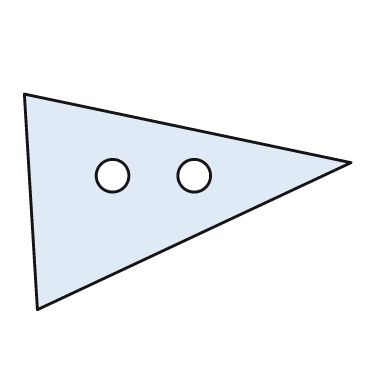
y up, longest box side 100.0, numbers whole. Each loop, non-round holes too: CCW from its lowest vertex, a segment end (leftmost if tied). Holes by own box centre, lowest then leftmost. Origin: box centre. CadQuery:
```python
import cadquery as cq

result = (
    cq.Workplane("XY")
    .moveTo(-46.0, -33.0)
    .lineTo(50.0, 12.0)
    .lineTo(-50.0, 33.0)
    .close()
    .moveTo(-23.0, 8.0)
    .circle(5.0)
    .moveTo(2.0, 8.0)
    .circle(5.0)
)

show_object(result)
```